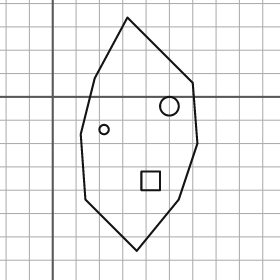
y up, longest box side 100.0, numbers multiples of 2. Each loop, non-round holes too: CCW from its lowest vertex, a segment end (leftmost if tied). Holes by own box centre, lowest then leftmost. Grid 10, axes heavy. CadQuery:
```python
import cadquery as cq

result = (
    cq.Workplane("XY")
    .moveTo(36.0, -66.0)
    .lineTo(54.0, -44.0)
    .lineTo(62.0, -20.0)
    .lineTo(60.0, 6.0)
    .lineTo(32.0, 34.0)
    .lineTo(18.0, 8.0)
    .lineTo(12.0, -16.0)
    .lineTo(14.0, -44.0)
    .close()
    .moveTo(38.0, -40.0)
    .lineTo(46.0, -40.0)
    .lineTo(46.0, -32.0)
    .lineTo(38.0, -32.0)
    .close()
    .moveTo(22.0, -14.0)
    .circle(2.0)
    .moveTo(50.0, -4.0)
    .circle(4.0)
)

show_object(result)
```